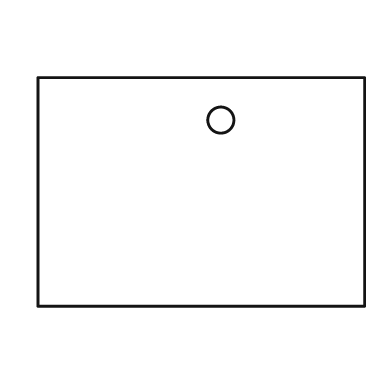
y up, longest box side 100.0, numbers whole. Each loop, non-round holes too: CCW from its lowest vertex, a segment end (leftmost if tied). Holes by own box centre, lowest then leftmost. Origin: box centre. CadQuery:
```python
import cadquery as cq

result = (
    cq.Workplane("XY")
    .moveTo(-50.0, -35.0)
    .lineTo(50.0, -35.0)
    .lineTo(50.0, 35.0)
    .lineTo(-50.0, 35.0)
    .close()
    .moveTo(6.0, 22.0)
    .circle(4.0)
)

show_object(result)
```